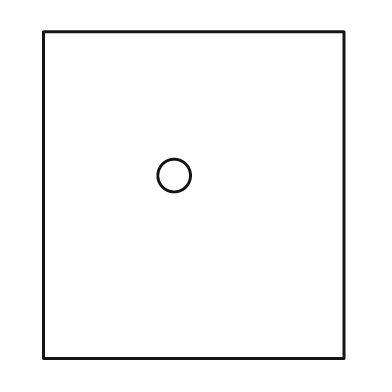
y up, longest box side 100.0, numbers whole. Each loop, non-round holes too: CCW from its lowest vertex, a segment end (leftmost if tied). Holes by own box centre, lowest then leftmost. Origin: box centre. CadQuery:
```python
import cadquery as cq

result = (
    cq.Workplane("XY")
    .moveTo(-46.0, -50.0)
    .lineTo(46.0, -50.0)
    .lineTo(46.0, 50.0)
    .lineTo(-46.0, 50.0)
    .close()
    .moveTo(-6.0, 6.0)
    .circle(5.0)
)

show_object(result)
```